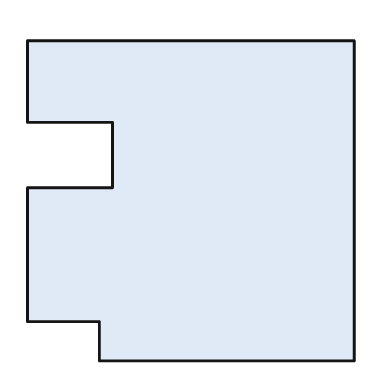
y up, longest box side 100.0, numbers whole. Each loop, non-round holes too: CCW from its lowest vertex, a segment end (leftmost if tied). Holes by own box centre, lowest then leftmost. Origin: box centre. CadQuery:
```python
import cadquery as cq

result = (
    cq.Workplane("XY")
    .moveTo(-28.0, -49.0)
    .lineTo(50.0, -49.0)
    .lineTo(50.0, 49.0)
    .lineTo(-50.0, 49.0)
    .lineTo(-50.0, 24.0)
    .lineTo(-24.0, 24.0)
    .lineTo(-24.0, 4.0)
    .lineTo(-50.0, 4.0)
    .lineTo(-50.0, -37.0)
    .lineTo(-28.0, -37.0)
    .close()
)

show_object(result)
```